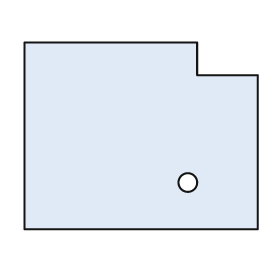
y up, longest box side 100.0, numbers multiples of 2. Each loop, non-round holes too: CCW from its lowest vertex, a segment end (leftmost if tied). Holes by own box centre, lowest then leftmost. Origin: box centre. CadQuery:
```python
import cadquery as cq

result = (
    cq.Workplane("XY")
    .moveTo(-50.0, -40.0)
    .lineTo(50.0, -40.0)
    .lineTo(50.0, 26.0)
    .lineTo(24.0, 26.0)
    .lineTo(24.0, 40.0)
    .lineTo(-50.0, 40.0)
    .close()
    .moveTo(20.0, -20.0)
    .circle(4.0)
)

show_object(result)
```